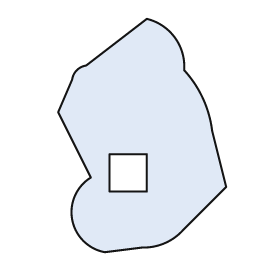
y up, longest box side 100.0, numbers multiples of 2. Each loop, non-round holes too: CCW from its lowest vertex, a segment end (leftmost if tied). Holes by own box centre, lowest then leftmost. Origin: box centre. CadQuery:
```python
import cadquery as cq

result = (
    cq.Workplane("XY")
    .moveTo(-16.0, -50.0)
    .lineTo(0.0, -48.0)
    .threePointArc((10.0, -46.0), (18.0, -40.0))
    .lineTo(36.0, -22.0)
    .lineTo(30.0, 2.0)
    .threePointArc((26.0, 16.0), (18.0, 28.0))
    .threePointArc((14.0, 42.0), (2.0, 50.0))
    .lineTo(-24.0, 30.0)
    .threePointArc((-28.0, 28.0), (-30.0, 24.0))
    .lineTo(-36.0, 10.0)
    .lineTo(-22.0, -18.0)
    .threePointArc((-30.0, -36.0), (-16.0, -50.0))
    .close()
    .moveTo(-14.0, -24.0)
    .lineTo(2.0, -24.0)
    .lineTo(2.0, -8.0)
    .lineTo(-14.0, -8.0)
    .close()
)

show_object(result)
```